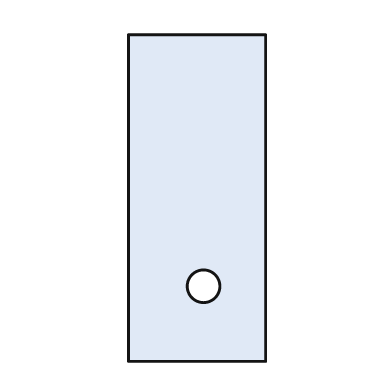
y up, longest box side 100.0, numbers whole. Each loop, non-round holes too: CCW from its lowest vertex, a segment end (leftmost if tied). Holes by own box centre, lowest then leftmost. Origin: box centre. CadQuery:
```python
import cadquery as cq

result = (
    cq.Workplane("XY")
    .moveTo(-21.0, -50.0)
    .lineTo(21.0, -50.0)
    .lineTo(21.0, 50.0)
    .lineTo(-21.0, 50.0)
    .close()
    .moveTo(2.0, -27.0)
    .circle(5.0)
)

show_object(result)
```